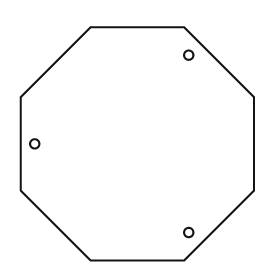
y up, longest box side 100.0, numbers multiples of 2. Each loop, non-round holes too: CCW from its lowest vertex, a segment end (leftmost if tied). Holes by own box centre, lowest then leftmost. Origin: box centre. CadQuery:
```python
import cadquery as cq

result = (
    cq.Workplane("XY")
    .moveTo(-20.0, -50.0)
    .lineTo(20.0, -50.0)
    .lineTo(50.0, -20.0)
    .lineTo(50.0, 20.0)
    .lineTo(20.0, 50.0)
    .lineTo(-20.0, 50.0)
    .lineTo(-50.0, 20.0)
    .lineTo(-50.0, -20.0)
    .close()
    .moveTo(22.0, -38.0)
    .circle(2.0)
    .moveTo(-44.0, 0.0)
    .circle(2.0)
    .moveTo(22.0, 38.0)
    .circle(2.0)
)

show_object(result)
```